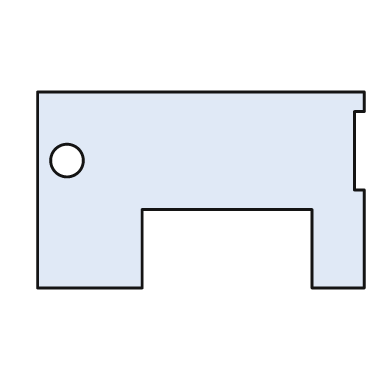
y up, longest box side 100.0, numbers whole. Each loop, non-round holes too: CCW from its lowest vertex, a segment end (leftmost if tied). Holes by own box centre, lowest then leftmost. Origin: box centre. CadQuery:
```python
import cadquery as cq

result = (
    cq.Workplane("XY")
    .moveTo(-50.0, -30.0)
    .lineTo(-18.0, -30.0)
    .lineTo(-18.0, -6.0)
    .lineTo(34.0, -6.0)
    .lineTo(34.0, -30.0)
    .lineTo(50.0, -30.0)
    .lineTo(50.0, 0.0)
    .lineTo(47.0, 0.0)
    .lineTo(47.0, 24.0)
    .lineTo(50.0, 24.0)
    .lineTo(50.0, 30.0)
    .lineTo(-50.0, 30.0)
    .close()
    .moveTo(-41.0, 9.0)
    .circle(5.0)
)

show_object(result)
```